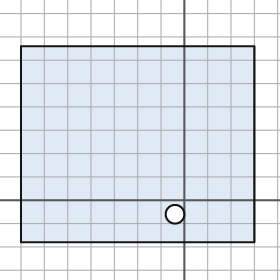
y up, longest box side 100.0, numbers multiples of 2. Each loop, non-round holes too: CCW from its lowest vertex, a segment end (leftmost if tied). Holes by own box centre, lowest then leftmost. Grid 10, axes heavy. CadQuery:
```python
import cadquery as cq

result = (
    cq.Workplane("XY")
    .moveTo(-70.0, -18.0)
    .lineTo(30.0, -18.0)
    .lineTo(30.0, 66.0)
    .lineTo(-70.0, 66.0)
    .close()
    .moveTo(-4.0, -6.0)
    .circle(4.0)
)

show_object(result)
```